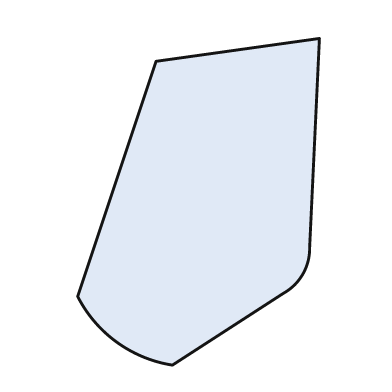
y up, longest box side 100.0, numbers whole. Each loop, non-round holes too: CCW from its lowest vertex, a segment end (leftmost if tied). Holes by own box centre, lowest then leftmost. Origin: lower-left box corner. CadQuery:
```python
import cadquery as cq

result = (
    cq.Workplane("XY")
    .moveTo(29.0, 0.0)
    .lineTo(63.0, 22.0)
    .threePointArc((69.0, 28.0), (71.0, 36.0))
    .lineTo(74.0, 100.0)
    .lineTo(24.0, 93.0)
    .lineTo(0.0, 21.0)
    .threePointArc((12.0, 7.0), (29.0, 0.0))
    .close()
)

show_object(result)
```